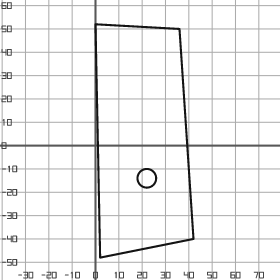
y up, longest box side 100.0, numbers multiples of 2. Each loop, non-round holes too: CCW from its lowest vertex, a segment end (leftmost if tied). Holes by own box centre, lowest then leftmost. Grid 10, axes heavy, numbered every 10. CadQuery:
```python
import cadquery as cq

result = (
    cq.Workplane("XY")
    .moveTo(2.0, -48.0)
    .lineTo(42.0, -40.0)
    .lineTo(36.0, 50.0)
    .lineTo(0.0, 52.0)
    .close()
    .moveTo(22.0, -14.0)
    .circle(4.0)
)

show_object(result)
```